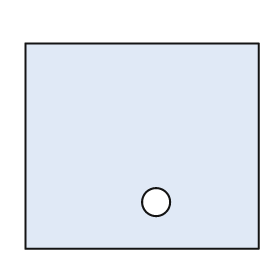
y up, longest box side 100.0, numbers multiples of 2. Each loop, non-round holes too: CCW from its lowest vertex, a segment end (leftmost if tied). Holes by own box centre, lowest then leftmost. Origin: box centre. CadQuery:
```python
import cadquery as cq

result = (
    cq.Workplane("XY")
    .moveTo(-50.0, -44.0)
    .lineTo(50.0, -44.0)
    .lineTo(50.0, 44.0)
    .lineTo(-50.0, 44.0)
    .close()
    .moveTo(6.0, -24.0)
    .circle(6.0)
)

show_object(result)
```